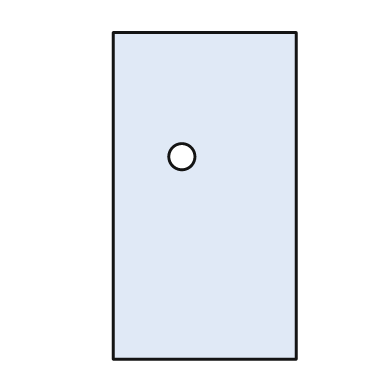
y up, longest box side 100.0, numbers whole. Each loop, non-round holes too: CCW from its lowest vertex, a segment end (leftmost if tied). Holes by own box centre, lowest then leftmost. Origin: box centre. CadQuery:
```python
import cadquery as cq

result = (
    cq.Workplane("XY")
    .moveTo(-28.0, -50.0)
    .lineTo(28.0, -50.0)
    .lineTo(28.0, 50.0)
    .lineTo(-28.0, 50.0)
    .close()
    .moveTo(-7.0, 12.0)
    .circle(4.0)
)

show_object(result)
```